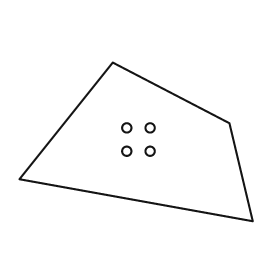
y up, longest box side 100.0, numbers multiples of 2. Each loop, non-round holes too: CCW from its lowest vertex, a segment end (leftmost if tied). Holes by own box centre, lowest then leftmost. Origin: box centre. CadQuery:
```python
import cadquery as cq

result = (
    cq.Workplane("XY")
    .moveTo(50.0, -34.0)
    .lineTo(40.0, 8.0)
    .lineTo(-10.0, 34.0)
    .lineTo(-50.0, -16.0)
    .close()
    .moveTo(-4.0, -4.0)
    .circle(2.0)
    .moveTo(6.0, -4.0)
    .circle(2.0)
    .moveTo(-4.0, 6.0)
    .circle(2.0)
    .moveTo(6.0, 6.0)
    .circle(2.0)
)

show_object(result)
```